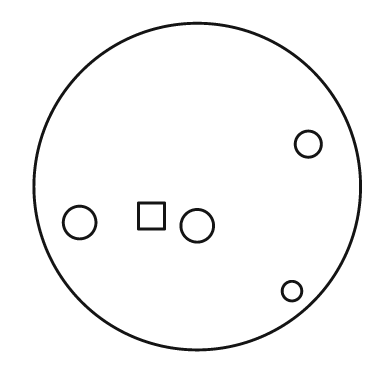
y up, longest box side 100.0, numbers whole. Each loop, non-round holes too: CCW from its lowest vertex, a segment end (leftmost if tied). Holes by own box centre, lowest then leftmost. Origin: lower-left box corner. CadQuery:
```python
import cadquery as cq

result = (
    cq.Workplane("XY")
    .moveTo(50.0, 50.0)
    .circle(50.0)
    .moveTo(79.0, 18.0)
    .circle(3.0)
    .moveTo(50.0, 38.0)
    .circle(5.0)
    .moveTo(14.0, 39.0)
    .circle(5.0)
    .moveTo(32.0, 37.0)
    .lineTo(40.0, 37.0)
    .lineTo(40.0, 45.0)
    .lineTo(32.0, 45.0)
    .close()
    .moveTo(84.0, 63.0)
    .circle(4.0)
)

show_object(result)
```